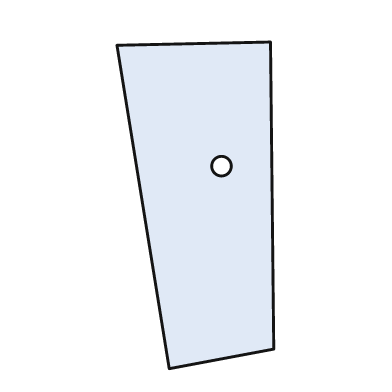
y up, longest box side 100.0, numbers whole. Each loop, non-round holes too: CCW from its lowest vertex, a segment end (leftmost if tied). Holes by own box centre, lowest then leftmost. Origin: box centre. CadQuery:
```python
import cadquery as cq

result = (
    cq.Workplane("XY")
    .moveTo(-8.0, -50.0)
    .lineTo(24.0, -44.0)
    .lineTo(23.0, 50.0)
    .lineTo(-24.0, 49.0)
    .close()
    .moveTo(8.0, 12.0)
    .circle(3.0)
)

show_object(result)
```